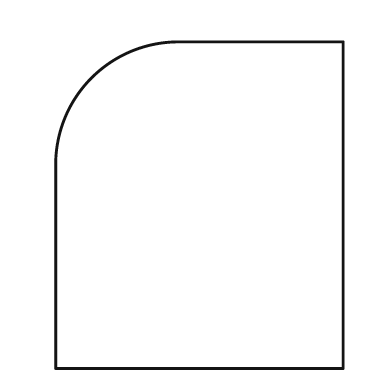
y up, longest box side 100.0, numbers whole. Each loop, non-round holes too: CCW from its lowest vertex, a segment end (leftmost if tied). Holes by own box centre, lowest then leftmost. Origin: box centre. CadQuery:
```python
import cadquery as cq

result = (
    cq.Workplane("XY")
    .moveTo(-44.0, -50.0)
    .lineTo(44.0, -50.0)
    .lineTo(44.0, 50.0)
    .lineTo(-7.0, 50.0)
    .threePointArc((-33.0, 39.0), (-44.0, 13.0))
    .close()
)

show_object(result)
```